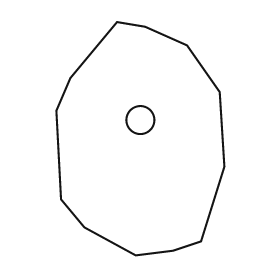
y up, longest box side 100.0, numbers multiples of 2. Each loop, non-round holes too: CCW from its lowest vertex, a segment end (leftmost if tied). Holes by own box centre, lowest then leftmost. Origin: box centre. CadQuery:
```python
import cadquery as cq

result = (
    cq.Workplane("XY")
    .moveTo(-2.0, -50.0)
    .lineTo(14.0, -48.0)
    .lineTo(26.0, -44.0)
    .lineTo(36.0, -12.0)
    .lineTo(34.0, 20.0)
    .lineTo(20.0, 40.0)
    .lineTo(2.0, 48.0)
    .lineTo(-10.0, 50.0)
    .lineTo(-30.0, 26.0)
    .lineTo(-36.0, 12.0)
    .lineTo(-34.0, -26.0)
    .lineTo(-24.0, -38.0)
    .close()
    .moveTo(0.0, 8.0)
    .circle(6.0)
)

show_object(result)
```